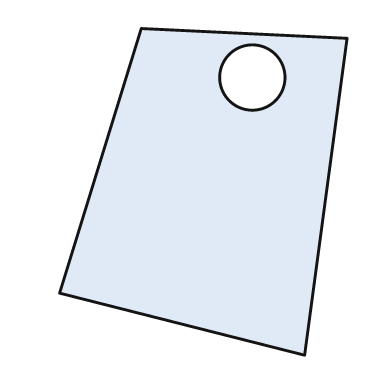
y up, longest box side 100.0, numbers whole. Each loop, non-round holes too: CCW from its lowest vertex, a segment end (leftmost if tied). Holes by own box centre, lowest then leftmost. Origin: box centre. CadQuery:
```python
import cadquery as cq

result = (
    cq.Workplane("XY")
    .moveTo(31.0, -50.0)
    .lineTo(44.0, 47.0)
    .lineTo(-19.0, 50.0)
    .lineTo(-44.0, -31.0)
    .close()
    .moveTo(15.0, 35.0)
    .circle(10.0)
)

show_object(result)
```